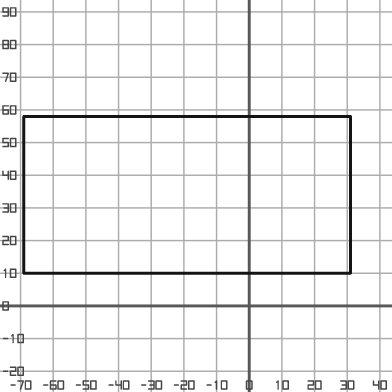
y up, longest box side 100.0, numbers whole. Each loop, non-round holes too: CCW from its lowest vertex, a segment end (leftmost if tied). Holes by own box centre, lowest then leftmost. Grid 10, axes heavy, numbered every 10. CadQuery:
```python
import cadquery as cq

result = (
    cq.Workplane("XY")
    .moveTo(-69.0, 10.0)
    .lineTo(31.0, 10.0)
    .lineTo(31.0, 58.0)
    .lineTo(-69.0, 58.0)
    .close()
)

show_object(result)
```